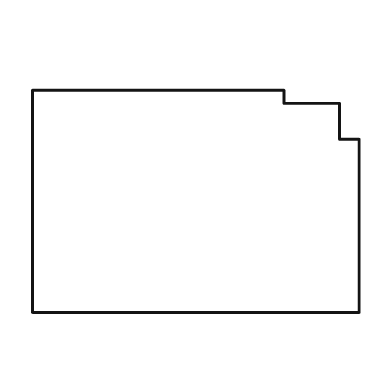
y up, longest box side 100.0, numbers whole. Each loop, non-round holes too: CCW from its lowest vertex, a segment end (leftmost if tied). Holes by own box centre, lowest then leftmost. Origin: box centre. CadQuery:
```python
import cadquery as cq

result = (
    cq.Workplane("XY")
    .moveTo(-50.0, -34.0)
    .lineTo(50.0, -34.0)
    .lineTo(50.0, 19.0)
    .lineTo(44.0, 19.0)
    .lineTo(44.0, 30.0)
    .lineTo(27.0, 30.0)
    .lineTo(27.0, 34.0)
    .lineTo(-50.0, 34.0)
    .close()
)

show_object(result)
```